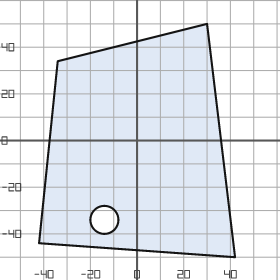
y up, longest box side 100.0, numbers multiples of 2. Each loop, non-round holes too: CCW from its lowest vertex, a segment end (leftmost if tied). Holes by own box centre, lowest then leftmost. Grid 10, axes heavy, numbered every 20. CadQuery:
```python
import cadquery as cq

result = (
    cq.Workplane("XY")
    .moveTo(42.0, -50.0)
    .lineTo(30.0, 50.0)
    .lineTo(-34.0, 34.0)
    .lineTo(-42.0, -44.0)
    .close()
    .moveTo(-14.0, -34.0)
    .circle(6.0)
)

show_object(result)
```